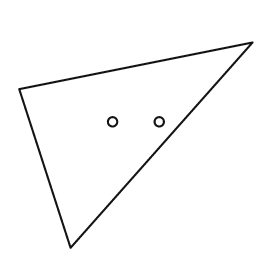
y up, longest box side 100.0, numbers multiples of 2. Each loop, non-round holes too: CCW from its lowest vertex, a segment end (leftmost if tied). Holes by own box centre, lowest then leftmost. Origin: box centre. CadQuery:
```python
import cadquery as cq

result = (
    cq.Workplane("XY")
    .moveTo(-28.0, -44.0)
    .lineTo(50.0, 44.0)
    .lineTo(-50.0, 24.0)
    .close()
    .moveTo(-10.0, 10.0)
    .circle(2.0)
    .moveTo(10.0, 10.0)
    .circle(2.0)
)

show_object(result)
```